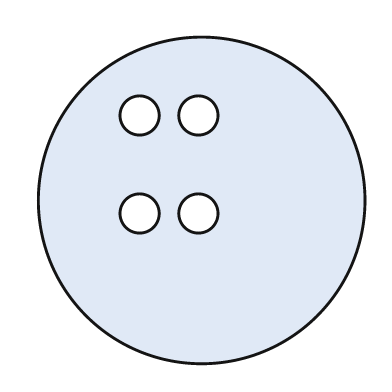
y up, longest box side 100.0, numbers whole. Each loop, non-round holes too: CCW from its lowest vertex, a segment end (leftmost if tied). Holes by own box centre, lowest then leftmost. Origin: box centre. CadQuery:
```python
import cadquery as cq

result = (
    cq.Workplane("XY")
    .moveTo(0.0, 0.0)
    .circle(50.0)
    .moveTo(-19.0, -4.0)
    .circle(6.0)
    .moveTo(-1.0, -4.0)
    .circle(6.0)
    .moveTo(-19.0, 26.0)
    .circle(6.0)
    .moveTo(-1.0, 26.0)
    .circle(6.0)
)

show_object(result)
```